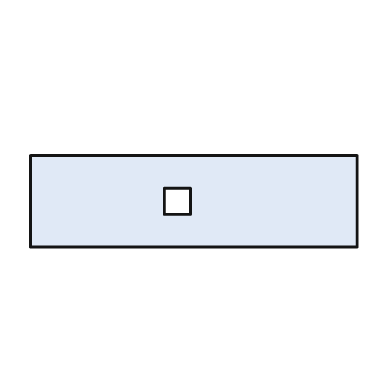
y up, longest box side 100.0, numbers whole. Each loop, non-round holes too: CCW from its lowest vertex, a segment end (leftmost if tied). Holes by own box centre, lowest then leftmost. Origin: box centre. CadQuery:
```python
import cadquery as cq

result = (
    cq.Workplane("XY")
    .moveTo(-50.0, -14.0)
    .lineTo(50.0, -14.0)
    .lineTo(50.0, 14.0)
    .lineTo(-50.0, 14.0)
    .close()
    .moveTo(-9.0, -4.0)
    .lineTo(-1.0, -4.0)
    .lineTo(-1.0, 4.0)
    .lineTo(-9.0, 4.0)
    .close()
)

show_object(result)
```